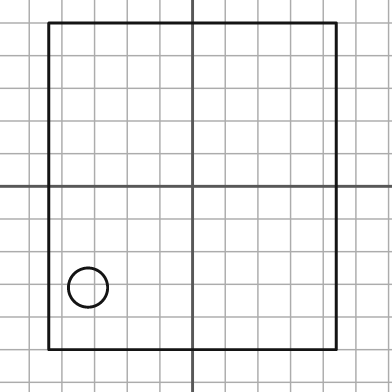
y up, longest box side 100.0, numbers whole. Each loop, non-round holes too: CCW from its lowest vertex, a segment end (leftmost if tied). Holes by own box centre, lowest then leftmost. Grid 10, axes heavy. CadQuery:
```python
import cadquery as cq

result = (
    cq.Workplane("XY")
    .moveTo(-44.0, -50.0)
    .lineTo(44.0, -50.0)
    .lineTo(44.0, 50.0)
    .lineTo(-44.0, 50.0)
    .close()
    .moveTo(-32.0, -31.0)
    .circle(6.0)
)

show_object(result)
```